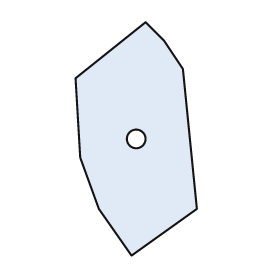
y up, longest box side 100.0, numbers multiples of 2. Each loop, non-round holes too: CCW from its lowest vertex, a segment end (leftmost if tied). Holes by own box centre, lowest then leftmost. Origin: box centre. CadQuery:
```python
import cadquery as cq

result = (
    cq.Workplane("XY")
    .moveTo(-2.0, -50.0)
    .lineTo(26.0, -30.0)
    .lineTo(20.0, 30.0)
    .lineTo(12.0, 42.0)
    .lineTo(4.0, 50.0)
    .lineTo(-26.0, 26.0)
    .lineTo(-24.0, -8.0)
    .lineTo(-16.0, -30.0)
    .close()
    .moveTo(0.0, 0.0)
    .circle(4.0)
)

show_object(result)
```